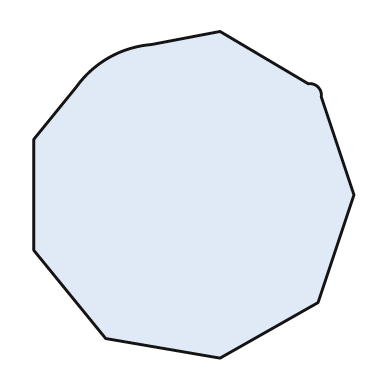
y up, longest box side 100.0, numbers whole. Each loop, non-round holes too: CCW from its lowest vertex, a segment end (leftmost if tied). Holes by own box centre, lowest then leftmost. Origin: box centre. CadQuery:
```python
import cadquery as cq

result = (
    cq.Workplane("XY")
    .moveTo(8.0, -50.0)
    .lineTo(38.0, -33.0)
    .lineTo(49.0, 0.0)
    .lineTo(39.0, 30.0)
    .threePointArc((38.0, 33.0), (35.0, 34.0))
    .lineTo(8.0, 50.0)
    .lineTo(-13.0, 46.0)
    .threePointArc((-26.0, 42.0), (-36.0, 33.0))
    .lineTo(-49.0, 17.0)
    .lineTo(-49.0, -17.0)
    .lineTo(-27.0, -44.0)
    .close()
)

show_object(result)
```